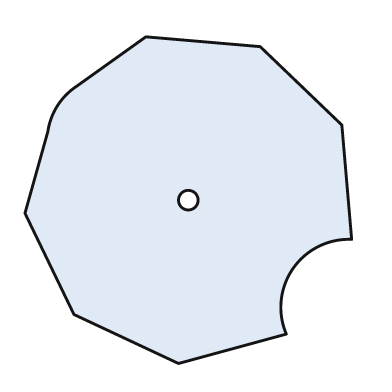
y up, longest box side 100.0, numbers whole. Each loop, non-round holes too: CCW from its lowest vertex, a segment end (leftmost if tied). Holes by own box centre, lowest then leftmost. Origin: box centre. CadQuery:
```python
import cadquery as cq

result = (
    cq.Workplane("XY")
    .moveTo(-3.0, -50.0)
    .lineTo(30.0, -41.0)
    .threePointArc((32.0, -21.0), (50.0, -12.0))
    .lineTo(47.0, 23.0)
    .lineTo(22.0, 47.0)
    .lineTo(-13.0, 50.0)
    .lineTo(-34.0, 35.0)
    .threePointArc((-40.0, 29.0), (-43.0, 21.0))
    .lineTo(-50.0, -4.0)
    .lineTo(-35.0, -35.0)
    .close()
    .moveTo(0.0, 0.0)
    .circle(3.0)
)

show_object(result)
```